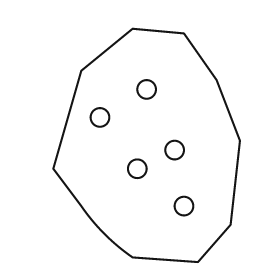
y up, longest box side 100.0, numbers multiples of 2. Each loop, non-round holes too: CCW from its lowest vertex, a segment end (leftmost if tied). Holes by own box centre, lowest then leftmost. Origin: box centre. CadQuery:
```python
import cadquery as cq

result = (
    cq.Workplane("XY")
    .moveTo(22.0, -50.0)
    .lineTo(36.0, -34.0)
    .lineTo(40.0, 2.0)
    .lineTo(30.0, 28.0)
    .lineTo(16.0, 48.0)
    .lineTo(-6.0, 50.0)
    .lineTo(-28.0, 32.0)
    .lineTo(-40.0, -10.0)
    .lineTo(-28.0, -26.0)
    .threePointArc((-18.0, -38.0), (-6.0, -48.0))
    .close()
    .moveTo(16.0, -26.0)
    .circle(4.0)
    .moveTo(-4.0, -10.0)
    .circle(4.0)
    .moveTo(12.0, -2.0)
    .circle(4.0)
    .moveTo(-20.0, 12.0)
    .circle(4.0)
    .moveTo(0.0, 24.0)
    .circle(4.0)
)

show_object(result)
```